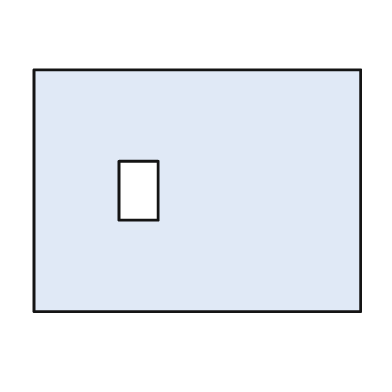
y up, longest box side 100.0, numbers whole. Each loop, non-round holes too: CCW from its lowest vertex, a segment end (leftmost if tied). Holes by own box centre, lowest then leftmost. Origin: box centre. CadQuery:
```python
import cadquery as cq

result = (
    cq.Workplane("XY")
    .moveTo(-50.0, -37.0)
    .lineTo(50.0, -37.0)
    .lineTo(50.0, 37.0)
    .lineTo(-50.0, 37.0)
    .close()
    .moveTo(-24.0, -9.0)
    .lineTo(-12.0, -9.0)
    .lineTo(-12.0, 9.0)
    .lineTo(-24.0, 9.0)
    .close()
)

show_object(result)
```